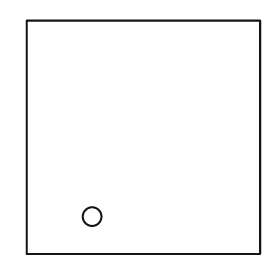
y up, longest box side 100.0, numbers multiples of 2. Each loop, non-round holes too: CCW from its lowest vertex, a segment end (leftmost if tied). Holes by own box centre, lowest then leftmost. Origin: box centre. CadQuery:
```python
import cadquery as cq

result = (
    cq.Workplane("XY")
    .moveTo(-50.0, -50.0)
    .lineTo(50.0, -50.0)
    .lineTo(50.0, 50.0)
    .lineTo(-50.0, 50.0)
    .close()
    .moveTo(-22.0, -34.0)
    .circle(4.0)
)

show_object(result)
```